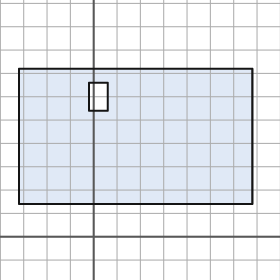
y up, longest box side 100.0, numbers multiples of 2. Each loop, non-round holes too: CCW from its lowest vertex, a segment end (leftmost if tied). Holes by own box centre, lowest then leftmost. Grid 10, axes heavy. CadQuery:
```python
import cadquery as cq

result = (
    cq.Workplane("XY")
    .moveTo(-32.0, 14.0)
    .lineTo(68.0, 14.0)
    .lineTo(68.0, 72.0)
    .lineTo(-32.0, 72.0)
    .close()
    .moveTo(-2.0, 54.0)
    .lineTo(6.0, 54.0)
    .lineTo(6.0, 66.0)
    .lineTo(-2.0, 66.0)
    .close()
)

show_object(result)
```